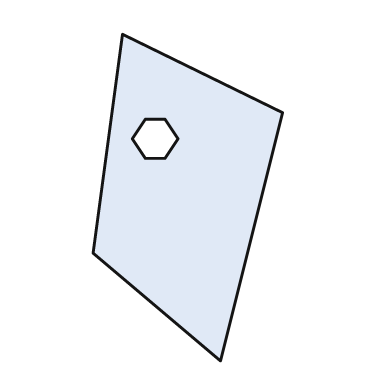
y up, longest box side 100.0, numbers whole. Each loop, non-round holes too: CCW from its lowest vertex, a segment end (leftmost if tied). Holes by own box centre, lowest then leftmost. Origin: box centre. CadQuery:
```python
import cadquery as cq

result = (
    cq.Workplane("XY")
    .moveTo(10.0, -50.0)
    .lineTo(29.0, 26.0)
    .lineTo(-20.0, 50.0)
    .lineTo(-29.0, -17.0)
    .close()
    .moveTo(-13.0, 12.0)
    .lineTo(-7.0, 12.0)
    .lineTo(-3.0, 18.0)
    .lineTo(-7.0, 24.0)
    .lineTo(-13.0, 24.0)
    .lineTo(-17.0, 18.0)
    .close()
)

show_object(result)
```